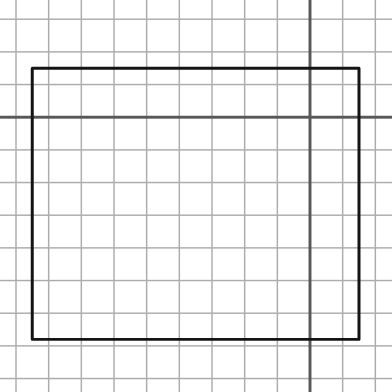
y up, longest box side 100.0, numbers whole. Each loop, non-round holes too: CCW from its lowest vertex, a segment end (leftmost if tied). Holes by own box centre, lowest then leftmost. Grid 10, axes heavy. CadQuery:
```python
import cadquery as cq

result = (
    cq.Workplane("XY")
    .moveTo(-85.0, -68.0)
    .lineTo(15.0, -68.0)
    .lineTo(15.0, 15.0)
    .lineTo(-85.0, 15.0)
    .close()
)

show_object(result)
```